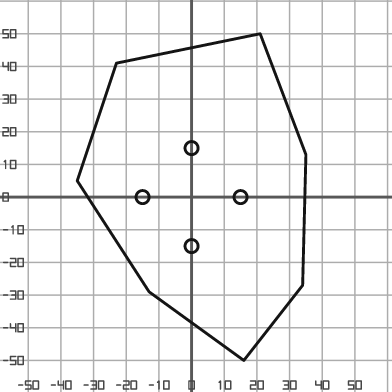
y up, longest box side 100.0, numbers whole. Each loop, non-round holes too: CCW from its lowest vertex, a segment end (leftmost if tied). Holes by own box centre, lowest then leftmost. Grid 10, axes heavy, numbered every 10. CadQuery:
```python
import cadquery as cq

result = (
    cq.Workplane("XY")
    .moveTo(16.0, -50.0)
    .lineTo(34.0, -27.0)
    .lineTo(35.0, 13.0)
    .lineTo(21.0, 50.0)
    .lineTo(-23.0, 41.0)
    .lineTo(-35.0, 5.0)
    .lineTo(-13.0, -29.0)
    .close()
    .moveTo(0.0, -15.0)
    .circle(2.0)
    .moveTo(-15.0, 0.0)
    .circle(2.0)
    .moveTo(15.0, 0.0)
    .circle(2.0)
    .moveTo(0.0, 15.0)
    .circle(2.0)
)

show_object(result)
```